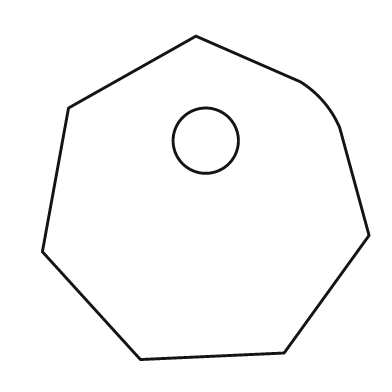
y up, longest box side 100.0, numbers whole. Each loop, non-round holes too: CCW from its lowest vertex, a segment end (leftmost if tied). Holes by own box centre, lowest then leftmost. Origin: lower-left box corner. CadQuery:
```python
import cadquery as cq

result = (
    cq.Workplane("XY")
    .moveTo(30.0, 0.0)
    .lineTo(74.0, 2.0)
    .lineTo(100.0, 38.0)
    .lineTo(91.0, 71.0)
    .threePointArc((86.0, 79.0), (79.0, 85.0))
    .lineTo(47.0, 99.0)
    .lineTo(8.0, 77.0)
    .lineTo(0.0, 33.0)
    .close()
    .moveTo(50.0, 67.0)
    .circle(10.0)
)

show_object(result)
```